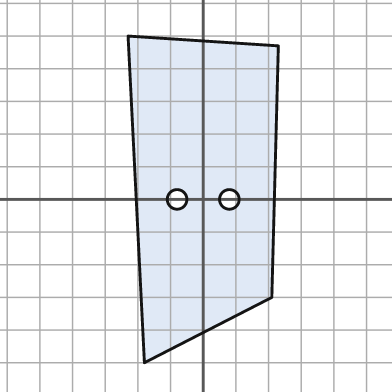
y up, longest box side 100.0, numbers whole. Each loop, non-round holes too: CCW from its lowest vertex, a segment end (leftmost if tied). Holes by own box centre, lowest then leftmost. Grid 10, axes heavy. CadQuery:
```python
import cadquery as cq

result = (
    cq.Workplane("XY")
    .moveTo(-18.0, -50.0)
    .lineTo(21.0, -30.0)
    .lineTo(23.0, 47.0)
    .lineTo(-23.0, 50.0)
    .close()
    .moveTo(-8.0, 0.0)
    .circle(3.0)
    .moveTo(8.0, 0.0)
    .circle(3.0)
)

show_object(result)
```